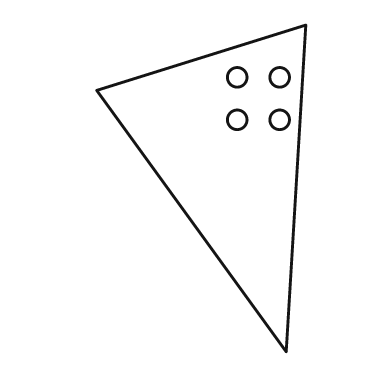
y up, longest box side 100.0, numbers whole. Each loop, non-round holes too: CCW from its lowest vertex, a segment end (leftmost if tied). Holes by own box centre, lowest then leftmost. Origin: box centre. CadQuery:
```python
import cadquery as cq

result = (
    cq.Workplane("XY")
    .moveTo(26.0, -50.0)
    .lineTo(32.0, 50.0)
    .lineTo(-32.0, 30.0)
    .close()
    .moveTo(11.0, 21.0)
    .circle(3.0)
    .moveTo(24.0, 21.0)
    .circle(3.0)
    .moveTo(11.0, 34.0)
    .circle(3.0)
    .moveTo(24.0, 34.0)
    .circle(3.0)
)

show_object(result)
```